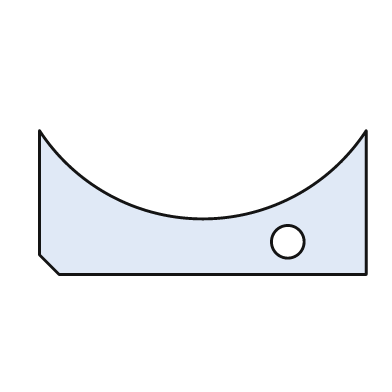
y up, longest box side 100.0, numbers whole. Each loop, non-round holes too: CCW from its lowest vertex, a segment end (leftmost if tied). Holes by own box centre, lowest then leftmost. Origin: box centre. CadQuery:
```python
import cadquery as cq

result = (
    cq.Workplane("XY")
    .moveTo(-44.0, -22.0)
    .lineTo(50.0, -22.0)
    .lineTo(50.0, 22.0)
    .threePointArc((0.0, -5.0), (-50.0, 22.0))
    .lineTo(-50.0, -16.0)
    .close()
    .moveTo(26.0, -12.0)
    .circle(5.0)
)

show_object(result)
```